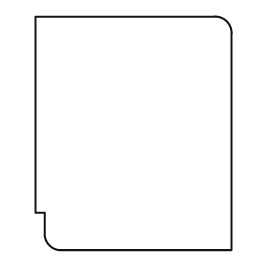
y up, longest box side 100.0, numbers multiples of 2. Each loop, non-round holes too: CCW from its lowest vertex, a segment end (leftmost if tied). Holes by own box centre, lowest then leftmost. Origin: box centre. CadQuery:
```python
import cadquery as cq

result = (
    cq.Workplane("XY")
    .moveTo(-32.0, -50.0)
    .lineTo(42.0, -50.0)
    .lineTo(42.0, 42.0)
    .threePointArc((40.0, 48.0), (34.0, 50.0))
    .lineTo(-42.0, 50.0)
    .lineTo(-42.0, -34.0)
    .lineTo(-38.0, -34.0)
    .lineTo(-38.0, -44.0)
    .threePointArc((-36.0, -48.0), (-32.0, -50.0))
    .close()
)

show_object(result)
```